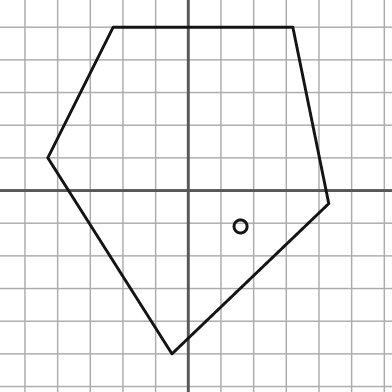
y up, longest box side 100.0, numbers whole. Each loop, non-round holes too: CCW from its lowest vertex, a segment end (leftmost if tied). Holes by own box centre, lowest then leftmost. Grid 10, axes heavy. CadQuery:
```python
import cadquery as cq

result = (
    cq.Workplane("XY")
    .moveTo(-5.0, -50.0)
    .lineTo(43.0, -4.0)
    .lineTo(32.0, 50.0)
    .lineTo(-23.0, 50.0)
    .lineTo(-43.0, 10.0)
    .close()
    .moveTo(16.0, -11.0)
    .circle(2.0)
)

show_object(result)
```